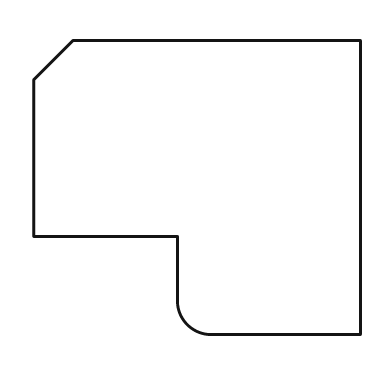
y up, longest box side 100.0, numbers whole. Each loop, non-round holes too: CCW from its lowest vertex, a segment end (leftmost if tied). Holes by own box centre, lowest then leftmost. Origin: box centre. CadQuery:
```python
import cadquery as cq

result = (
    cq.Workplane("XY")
    .moveTo(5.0, -45.0)
    .lineTo(50.0, -45.0)
    .lineTo(50.0, 45.0)
    .lineTo(-38.0, 45.0)
    .lineTo(-50.0, 33.0)
    .lineTo(-50.0, -15.0)
    .lineTo(-6.0, -15.0)
    .lineTo(-6.0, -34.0)
    .threePointArc((-3.0, -42.0), (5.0, -45.0))
    .close()
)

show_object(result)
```